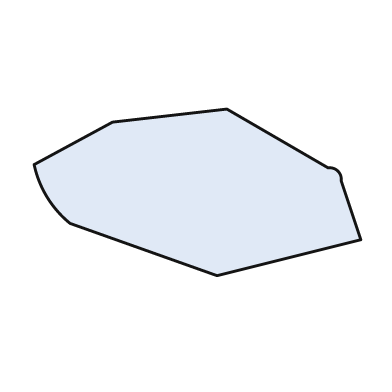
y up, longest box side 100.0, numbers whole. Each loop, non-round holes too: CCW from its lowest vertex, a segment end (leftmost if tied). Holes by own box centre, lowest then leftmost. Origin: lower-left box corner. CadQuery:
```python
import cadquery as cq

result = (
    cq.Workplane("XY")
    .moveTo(56.0, 0.0)
    .lineTo(100.0, 11.0)
    .lineTo(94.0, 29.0)
    .threePointArc((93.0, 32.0), (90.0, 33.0))
    .lineTo(59.0, 51.0)
    .lineTo(24.0, 47.0)
    .lineTo(0.0, 34.0)
    .threePointArc((4.0, 24.0), (11.0, 16.0))
    .close()
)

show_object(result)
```